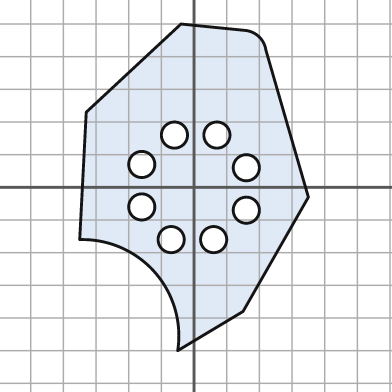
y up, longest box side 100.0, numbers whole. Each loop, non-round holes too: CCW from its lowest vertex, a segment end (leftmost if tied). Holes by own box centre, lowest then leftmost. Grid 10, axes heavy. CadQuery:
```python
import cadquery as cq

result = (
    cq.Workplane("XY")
    .moveTo(-5.0, -50.0)
    .lineTo(15.0, -38.0)
    .lineTo(35.0, -3.0)
    .lineTo(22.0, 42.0)
    .threePointArc((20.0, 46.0), (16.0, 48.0))
    .lineTo(-4.0, 50.0)
    .lineTo(-33.0, 23.0)
    .lineTo(-35.0, -16.0)
    .threePointArc((-12.0, -26.0), (-5.0, -50.0))
    .close()
    .moveTo(-7.0, -16.0)
    .circle(4.0)
    .moveTo(6.0, -16.0)
    .circle(4.0)
    .moveTo(16.0, -7.0)
    .circle(4.0)
    .moveTo(-16.0, -6.0)
    .circle(4.0)
    .moveTo(16.0, 6.0)
    .circle(4.0)
    .moveTo(-16.0, 7.0)
    .circle(4.0)
    .moveTo(-6.0, 16.0)
    .circle(4.0)
    .moveTo(7.0, 16.0)
    .circle(4.0)
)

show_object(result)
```